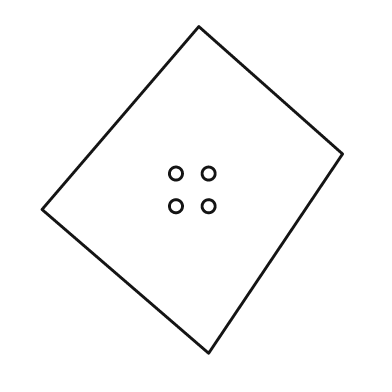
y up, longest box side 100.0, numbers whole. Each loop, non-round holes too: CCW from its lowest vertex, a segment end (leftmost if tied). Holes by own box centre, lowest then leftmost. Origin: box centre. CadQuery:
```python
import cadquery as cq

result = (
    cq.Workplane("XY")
    .moveTo(5.0, -50.0)
    .lineTo(46.0, 11.0)
    .lineTo(2.0, 50.0)
    .lineTo(-46.0, -6.0)
    .close()
    .moveTo(-5.0, -5.0)
    .circle(2.0)
    .moveTo(5.0, -5.0)
    .circle(2.0)
    .moveTo(-5.0, 5.0)
    .circle(2.0)
    .moveTo(5.0, 5.0)
    .circle(2.0)
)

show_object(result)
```